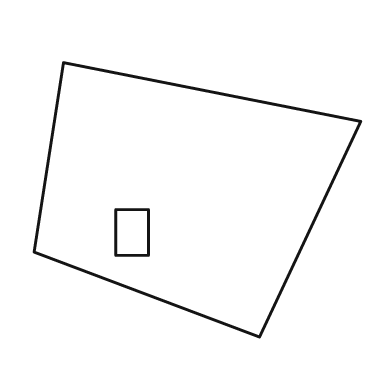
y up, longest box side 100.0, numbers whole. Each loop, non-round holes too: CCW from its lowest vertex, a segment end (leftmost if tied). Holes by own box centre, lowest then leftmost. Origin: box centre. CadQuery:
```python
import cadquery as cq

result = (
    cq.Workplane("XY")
    .moveTo(19.0, -42.0)
    .lineTo(50.0, 24.0)
    .lineTo(-41.0, 42.0)
    .lineTo(-50.0, -16.0)
    .close()
    .moveTo(-25.0, -17.0)
    .lineTo(-15.0, -17.0)
    .lineTo(-15.0, -3.0)
    .lineTo(-25.0, -3.0)
    .close()
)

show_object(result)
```